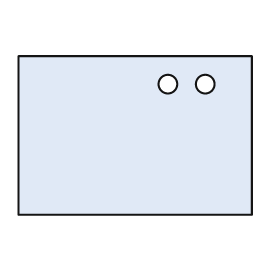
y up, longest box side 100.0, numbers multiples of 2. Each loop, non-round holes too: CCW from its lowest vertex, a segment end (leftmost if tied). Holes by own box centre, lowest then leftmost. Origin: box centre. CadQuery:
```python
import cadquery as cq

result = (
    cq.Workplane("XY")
    .moveTo(-50.0, -34.0)
    .lineTo(50.0, -34.0)
    .lineTo(50.0, 34.0)
    .lineTo(-50.0, 34.0)
    .close()
    .moveTo(14.0, 22.0)
    .circle(4.0)
    .moveTo(30.0, 22.0)
    .circle(4.0)
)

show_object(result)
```